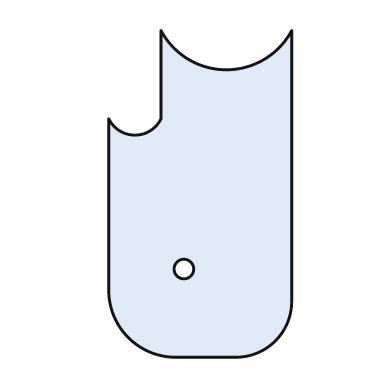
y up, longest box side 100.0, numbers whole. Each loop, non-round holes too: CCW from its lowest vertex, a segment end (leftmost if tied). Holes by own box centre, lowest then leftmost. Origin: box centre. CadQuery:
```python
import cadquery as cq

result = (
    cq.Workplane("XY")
    .moveTo(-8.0, -50.0)
    .lineTo(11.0, -50.0)
    .threePointArc((23.0, -45.0), (28.0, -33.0))
    .lineTo(28.0, 50.0)
    .threePointArc((8.0, 38.0), (-12.0, 50.0))
    .lineTo(-12.0, 23.0)
    .threePointArc((-20.0, 18.0), (-28.0, 23.0))
    .lineTo(-28.0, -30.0)
    .threePointArc((-22.0, -44.0), (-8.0, -50.0))
    .close()
    .moveTo(-5.0, -23.0)
    .circle(3.0)
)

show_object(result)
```